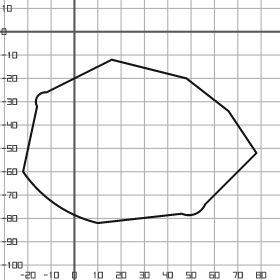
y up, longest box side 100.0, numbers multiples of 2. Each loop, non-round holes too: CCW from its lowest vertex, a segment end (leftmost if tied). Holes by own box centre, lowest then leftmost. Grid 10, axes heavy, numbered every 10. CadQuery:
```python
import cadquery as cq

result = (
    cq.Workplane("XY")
    .moveTo(10.0, -82.0)
    .lineTo(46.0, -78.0)
    .threePointArc((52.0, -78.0), (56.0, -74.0))
    .lineTo(78.0, -52.0)
    .lineTo(66.0, -34.0)
    .lineTo(48.0, -20.0)
    .lineTo(16.0, -12.0)
    .lineTo(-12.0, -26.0)
    .threePointArc((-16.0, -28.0), (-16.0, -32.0))
    .lineTo(-22.0, -60.0)
    .threePointArc((-8.0, -74.0), (10.0, -82.0))
    .close()
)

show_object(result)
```